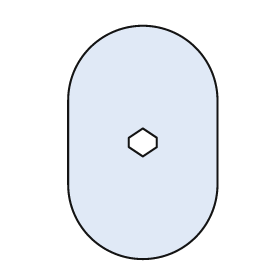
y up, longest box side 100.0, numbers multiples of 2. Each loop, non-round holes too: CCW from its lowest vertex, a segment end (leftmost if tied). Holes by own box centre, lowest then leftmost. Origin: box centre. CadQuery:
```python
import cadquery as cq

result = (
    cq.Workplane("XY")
    .moveTo(-32.0, -18.0)
    .threePointArc((0.0, -50.0), (32.0, -18.0))
    .lineTo(32.0, 18.0)
    .threePointArc((0.0, 50.0), (-32.0, 18.0))
    .close()
    .moveTo(0.0, -6.0)
    .lineTo(6.0, -2.0)
    .lineTo(6.0, 2.0)
    .lineTo(0.0, 6.0)
    .lineTo(-6.0, 2.0)
    .lineTo(-6.0, -2.0)
    .close()
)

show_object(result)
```